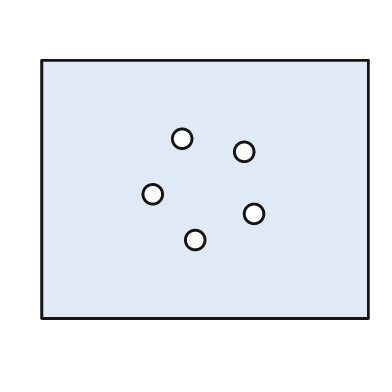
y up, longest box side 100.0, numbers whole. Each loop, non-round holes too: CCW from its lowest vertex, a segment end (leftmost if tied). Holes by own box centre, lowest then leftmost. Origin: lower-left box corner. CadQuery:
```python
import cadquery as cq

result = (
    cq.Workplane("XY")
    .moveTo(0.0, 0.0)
    .lineTo(100.0, 0.0)
    .lineTo(100.0, 79.0)
    .lineTo(0.0, 79.0)
    .close()
    .moveTo(47.0, 24.0)
    .circle(3.0)
    .moveTo(65.0, 32.0)
    .circle(3.0)
    .moveTo(34.0, 38.0)
    .circle(3.0)
    .moveTo(62.0, 51.0)
    .circle(3.0)
    .moveTo(43.0, 55.0)
    .circle(3.0)
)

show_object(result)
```